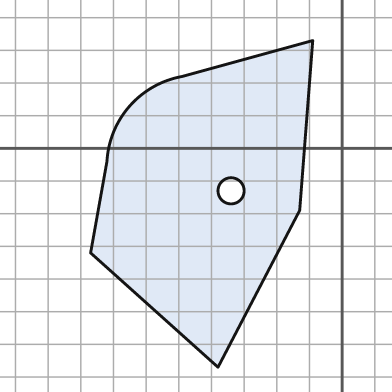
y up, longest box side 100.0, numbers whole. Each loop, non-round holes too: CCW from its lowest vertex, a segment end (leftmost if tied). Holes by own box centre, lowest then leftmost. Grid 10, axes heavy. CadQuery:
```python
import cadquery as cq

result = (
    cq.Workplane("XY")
    .moveTo(-38.0, -67.0)
    .lineTo(-13.0, -19.0)
    .lineTo(-9.0, 33.0)
    .lineTo(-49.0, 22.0)
    .threePointArc((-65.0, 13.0), (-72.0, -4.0))
    .lineTo(-77.0, -32.0)
    .close()
    .moveTo(-34.0, -13.0)
    .circle(4.0)
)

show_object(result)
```